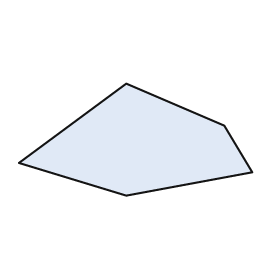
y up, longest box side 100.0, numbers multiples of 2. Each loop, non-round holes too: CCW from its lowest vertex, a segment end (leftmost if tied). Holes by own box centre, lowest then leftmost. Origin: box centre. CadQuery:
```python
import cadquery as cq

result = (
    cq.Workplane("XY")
    .moveTo(-4.0, -24.0)
    .lineTo(50.0, -14.0)
    .lineTo(38.0, 6.0)
    .lineTo(-4.0, 24.0)
    .lineTo(-50.0, -10.0)
    .close()
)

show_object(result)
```